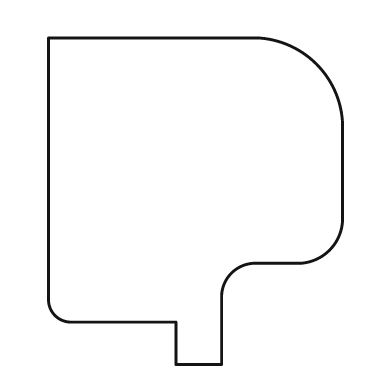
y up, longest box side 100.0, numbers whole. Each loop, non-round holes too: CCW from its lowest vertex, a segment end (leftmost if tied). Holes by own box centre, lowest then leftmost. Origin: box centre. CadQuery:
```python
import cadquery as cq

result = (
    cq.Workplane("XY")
    .moveTo(-6.0, -50.0)
    .lineTo(8.0, -50.0)
    .lineTo(8.0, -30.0)
    .threePointArc((11.0, -22.0), (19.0, -19.0))
    .lineTo(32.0, -19.0)
    .threePointArc((41.0, -15.0), (45.0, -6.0))
    .lineTo(45.0, 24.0)
    .threePointArc((37.0, 42.0), (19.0, 50.0))
    .lineTo(-45.0, 50.0)
    .lineTo(-45.0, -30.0)
    .threePointArc((-43.0, -35.0), (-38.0, -37.0))
    .lineTo(-6.0, -37.0)
    .close()
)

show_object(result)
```